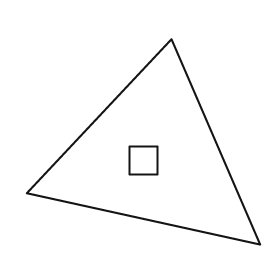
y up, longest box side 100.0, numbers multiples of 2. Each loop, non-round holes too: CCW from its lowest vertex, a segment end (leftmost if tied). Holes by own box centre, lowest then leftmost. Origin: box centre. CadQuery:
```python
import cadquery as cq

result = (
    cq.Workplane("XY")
    .moveTo(50.0, -44.0)
    .lineTo(12.0, 44.0)
    .lineTo(-50.0, -22.0)
    .close()
    .moveTo(-6.0, -14.0)
    .lineTo(6.0, -14.0)
    .lineTo(6.0, -2.0)
    .lineTo(-6.0, -2.0)
    .close()
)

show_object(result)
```